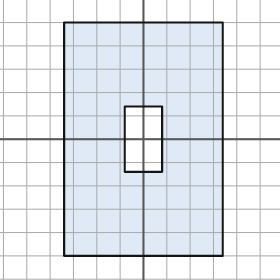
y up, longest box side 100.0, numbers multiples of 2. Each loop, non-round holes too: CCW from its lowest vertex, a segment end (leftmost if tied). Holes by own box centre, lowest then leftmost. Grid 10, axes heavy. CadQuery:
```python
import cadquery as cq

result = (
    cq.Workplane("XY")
    .moveTo(-34.0, -50.0)
    .lineTo(34.0, -50.0)
    .lineTo(34.0, 50.0)
    .lineTo(-34.0, 50.0)
    .close()
    .moveTo(-8.0, -14.0)
    .lineTo(8.0, -14.0)
    .lineTo(8.0, 14.0)
    .lineTo(-8.0, 14.0)
    .close()
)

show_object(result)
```